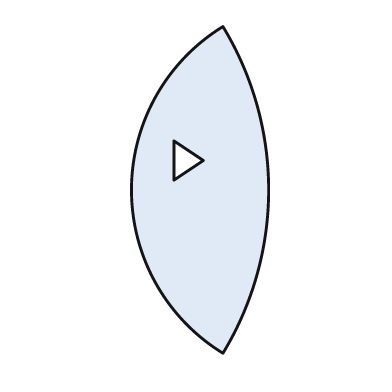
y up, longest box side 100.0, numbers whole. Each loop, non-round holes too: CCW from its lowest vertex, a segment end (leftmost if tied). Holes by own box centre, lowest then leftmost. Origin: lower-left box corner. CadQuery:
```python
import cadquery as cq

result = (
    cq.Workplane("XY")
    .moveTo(28.0, 0.0)
    .threePointArc((42.0, 50.0), (28.0, 100.0))
    .threePointArc((0.0, 50.0), (28.0, 0.0))
    .close()
    .moveTo(13.0, 53.0)
    .lineTo(22.0, 59.0)
    .lineTo(13.0, 65.0)
    .close()
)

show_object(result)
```